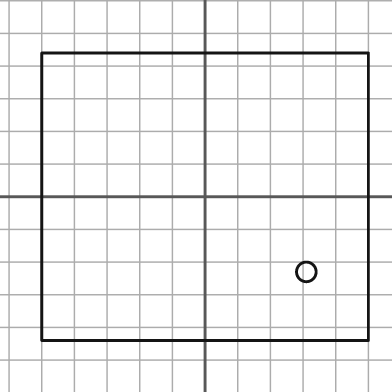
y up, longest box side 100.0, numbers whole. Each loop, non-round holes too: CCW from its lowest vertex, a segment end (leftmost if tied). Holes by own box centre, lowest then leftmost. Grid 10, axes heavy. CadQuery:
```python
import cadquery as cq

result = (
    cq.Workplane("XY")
    .moveTo(-50.0, -44.0)
    .lineTo(50.0, -44.0)
    .lineTo(50.0, 44.0)
    .lineTo(-50.0, 44.0)
    .close()
    .moveTo(31.0, -23.0)
    .circle(3.0)
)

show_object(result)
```